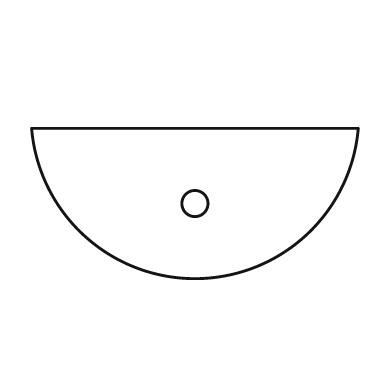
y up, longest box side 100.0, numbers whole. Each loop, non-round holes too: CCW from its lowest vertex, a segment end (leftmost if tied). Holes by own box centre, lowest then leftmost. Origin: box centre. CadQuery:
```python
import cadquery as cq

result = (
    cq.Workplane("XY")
    .moveTo(-50.0, 23.0)
    .threePointArc((0.0, -23.0), (50.0, 23.0))
    .close()
    .moveTo(0.0, 0.0)
    .circle(4.0)
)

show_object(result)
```